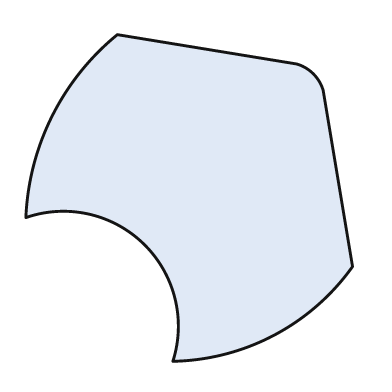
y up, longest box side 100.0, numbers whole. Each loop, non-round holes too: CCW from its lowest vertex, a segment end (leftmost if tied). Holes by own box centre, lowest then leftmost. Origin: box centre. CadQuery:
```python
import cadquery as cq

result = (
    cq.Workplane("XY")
    .moveTo(-5.0, -50.0)
    .threePointArc((26.0, -42.0), (50.0, -21.0))
    .lineTo(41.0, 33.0)
    .threePointArc((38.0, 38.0), (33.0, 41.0))
    .lineTo(-22.0, 50.0)
    .threePointArc((-42.0, 25.0), (-50.0, -6.0))
    .threePointArc((-14.0, -14.0), (-5.0, -50.0))
    .close()
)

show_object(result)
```